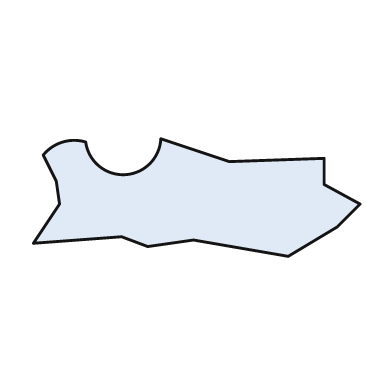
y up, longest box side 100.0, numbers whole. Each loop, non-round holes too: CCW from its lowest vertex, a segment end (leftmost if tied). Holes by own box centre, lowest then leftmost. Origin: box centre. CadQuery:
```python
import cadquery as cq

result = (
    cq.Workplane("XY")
    .moveTo(28.0, -18.0)
    .lineTo(43.0, -9.0)
    .lineTo(50.0, -2.0)
    .lineTo(39.0, 4.0)
    .lineTo(39.0, 12.0)
    .lineTo(10.0, 11.0)
    .lineTo(-11.0, 18.0)
    .threePointArc((-22.0, 7.0), (-34.0, 17.0))
    .threePointArc((-41.0, 17.0), (-47.0, 13.0))
    .lineTo(-43.0, 5.0)
    .lineTo(-42.0, -2.0)
    .lineTo(-50.0, -14.0)
    .lineTo(-23.0, -12.0)
    .lineTo(-15.0, -15.0)
    .lineTo(-1.0, -13.0)
    .close()
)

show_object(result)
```